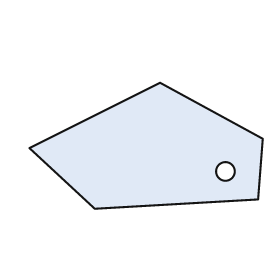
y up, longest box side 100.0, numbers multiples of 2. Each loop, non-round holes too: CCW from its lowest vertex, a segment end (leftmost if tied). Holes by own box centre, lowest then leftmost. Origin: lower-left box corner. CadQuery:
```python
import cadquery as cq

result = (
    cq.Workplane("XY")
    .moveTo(28.0, 0.0)
    .lineTo(98.0, 4.0)
    .lineTo(100.0, 30.0)
    .lineTo(56.0, 54.0)
    .lineTo(0.0, 26.0)
    .close()
    .moveTo(84.0, 16.0)
    .circle(4.0)
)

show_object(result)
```